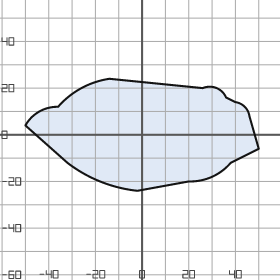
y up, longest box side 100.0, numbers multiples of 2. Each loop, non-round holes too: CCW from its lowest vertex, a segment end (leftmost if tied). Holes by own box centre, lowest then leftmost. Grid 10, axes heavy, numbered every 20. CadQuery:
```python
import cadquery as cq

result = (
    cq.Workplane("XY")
    .moveTo(-2.0, -24.0)
    .lineTo(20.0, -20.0)
    .threePointArc((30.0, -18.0), (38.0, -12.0))
    .lineTo(50.0, -6.0)
    .lineTo(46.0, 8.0)
    .threePointArc((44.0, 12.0), (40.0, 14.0))
    .lineTo(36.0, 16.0)
    .threePointArc((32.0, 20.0), (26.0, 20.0))
    .lineTo(-14.0, 24.0)
    .threePointArc((-26.0, 20.0), (-36.0, 12.0))
    .threePointArc((-44.0, 10.0), (-50.0, 4.0))
    .lineTo(-32.0, -12.0)
    .threePointArc((-18.0, -20.0), (-2.0, -24.0))
    .close()
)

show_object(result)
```